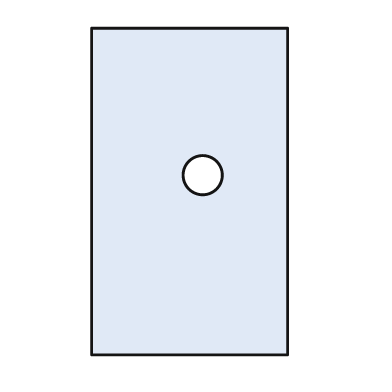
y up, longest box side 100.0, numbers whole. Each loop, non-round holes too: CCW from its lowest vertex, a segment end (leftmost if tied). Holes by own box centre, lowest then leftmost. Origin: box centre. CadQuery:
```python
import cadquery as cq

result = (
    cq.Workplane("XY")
    .moveTo(-30.0, -50.0)
    .lineTo(30.0, -50.0)
    .lineTo(30.0, 50.0)
    .lineTo(-30.0, 50.0)
    .close()
    .moveTo(4.0, 5.0)
    .circle(6.0)
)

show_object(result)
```